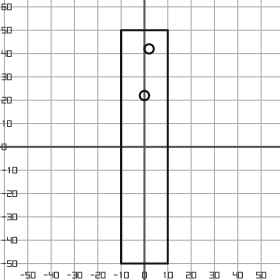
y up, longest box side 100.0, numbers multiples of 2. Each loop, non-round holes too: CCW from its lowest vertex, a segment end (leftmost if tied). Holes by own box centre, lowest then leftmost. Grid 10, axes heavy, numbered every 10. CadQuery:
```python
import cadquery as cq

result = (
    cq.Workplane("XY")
    .moveTo(-10.0, -50.0)
    .lineTo(10.0, -50.0)
    .lineTo(10.0, 50.0)
    .lineTo(-10.0, 50.0)
    .close()
    .moveTo(0.0, 22.0)
    .circle(2.0)
    .moveTo(2.0, 42.0)
    .circle(2.0)
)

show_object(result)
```